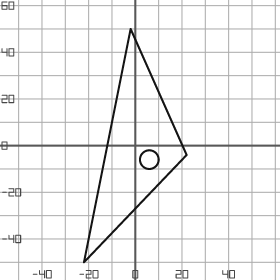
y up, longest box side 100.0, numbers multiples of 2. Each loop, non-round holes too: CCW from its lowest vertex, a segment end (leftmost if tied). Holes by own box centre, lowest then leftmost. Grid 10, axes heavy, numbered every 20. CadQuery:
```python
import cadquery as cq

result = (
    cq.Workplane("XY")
    .moveTo(-22.0, -50.0)
    .lineTo(22.0, -4.0)
    .lineTo(-2.0, 50.0)
    .close()
    .moveTo(6.0, -6.0)
    .circle(4.0)
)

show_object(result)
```